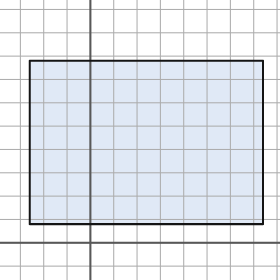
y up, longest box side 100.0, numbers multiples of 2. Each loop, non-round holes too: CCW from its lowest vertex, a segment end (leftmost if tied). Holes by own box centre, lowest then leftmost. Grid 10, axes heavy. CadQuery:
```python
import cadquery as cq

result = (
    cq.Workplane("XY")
    .moveTo(-26.0, 8.0)
    .lineTo(74.0, 8.0)
    .lineTo(74.0, 78.0)
    .lineTo(-26.0, 78.0)
    .close()
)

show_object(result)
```